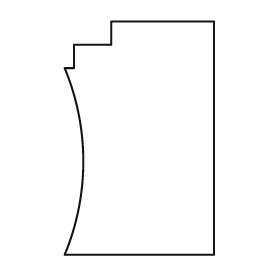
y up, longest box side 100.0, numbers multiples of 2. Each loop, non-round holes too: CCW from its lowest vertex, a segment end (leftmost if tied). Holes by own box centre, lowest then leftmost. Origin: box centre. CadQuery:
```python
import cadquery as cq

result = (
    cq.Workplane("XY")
    .moveTo(-32.0, -50.0)
    .lineTo(32.0, -50.0)
    .lineTo(32.0, 50.0)
    .lineTo(-12.0, 50.0)
    .lineTo(-12.0, 40.0)
    .lineTo(-28.0, 40.0)
    .lineTo(-28.0, 30.0)
    .lineTo(-32.0, 30.0)
    .threePointArc((-24.0, -10.0), (-32.0, -50.0))
    .close()
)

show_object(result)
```